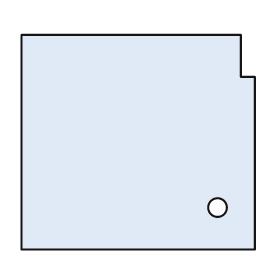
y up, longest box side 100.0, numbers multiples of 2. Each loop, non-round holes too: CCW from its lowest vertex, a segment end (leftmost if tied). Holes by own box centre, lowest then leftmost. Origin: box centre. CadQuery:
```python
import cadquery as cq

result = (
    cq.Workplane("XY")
    .moveTo(-50.0, -46.0)
    .lineTo(50.0, -46.0)
    .lineTo(50.0, 28.0)
    .lineTo(44.0, 28.0)
    .lineTo(44.0, 46.0)
    .lineTo(-50.0, 46.0)
    .close()
    .moveTo(34.0, -28.0)
    .circle(4.0)
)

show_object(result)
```